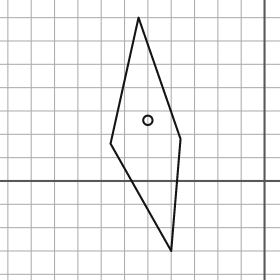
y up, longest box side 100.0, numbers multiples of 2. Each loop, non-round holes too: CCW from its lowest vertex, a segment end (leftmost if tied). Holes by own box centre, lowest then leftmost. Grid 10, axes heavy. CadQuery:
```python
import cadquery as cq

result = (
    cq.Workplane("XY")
    .moveTo(-40.0, -30.0)
    .lineTo(-36.0, 18.0)
    .lineTo(-54.0, 70.0)
    .lineTo(-66.0, 16.0)
    .close()
    .moveTo(-50.0, 26.0)
    .circle(2.0)
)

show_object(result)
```